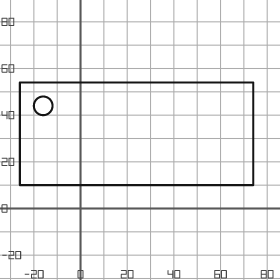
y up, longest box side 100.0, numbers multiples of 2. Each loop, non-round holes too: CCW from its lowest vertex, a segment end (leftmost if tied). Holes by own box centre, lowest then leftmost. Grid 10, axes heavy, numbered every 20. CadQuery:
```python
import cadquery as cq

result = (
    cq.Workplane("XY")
    .moveTo(-26.0, 10.0)
    .lineTo(74.0, 10.0)
    .lineTo(74.0, 54.0)
    .lineTo(-26.0, 54.0)
    .close()
    .moveTo(-16.0, 44.0)
    .circle(4.0)
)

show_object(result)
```